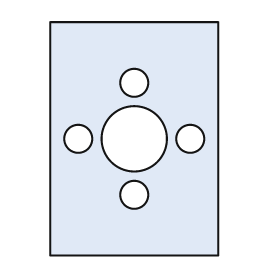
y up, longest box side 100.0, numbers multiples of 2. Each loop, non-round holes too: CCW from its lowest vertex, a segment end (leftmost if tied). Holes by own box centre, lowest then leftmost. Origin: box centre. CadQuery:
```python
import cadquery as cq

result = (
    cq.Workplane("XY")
    .moveTo(-36.0, -50.0)
    .lineTo(36.0, -50.0)
    .lineTo(36.0, 50.0)
    .lineTo(-36.0, 50.0)
    .close()
    .moveTo(0.0, -24.0)
    .circle(6.0)
    .moveTo(-24.0, 0.0)
    .circle(6.0)
    .moveTo(0.0, 0.0)
    .circle(14.0)
    .moveTo(24.0, 0.0)
    .circle(6.0)
    .moveTo(0.0, 24.0)
    .circle(6.0)
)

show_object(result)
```